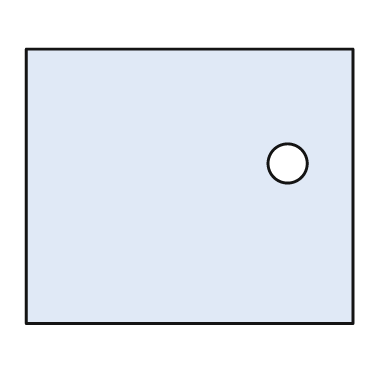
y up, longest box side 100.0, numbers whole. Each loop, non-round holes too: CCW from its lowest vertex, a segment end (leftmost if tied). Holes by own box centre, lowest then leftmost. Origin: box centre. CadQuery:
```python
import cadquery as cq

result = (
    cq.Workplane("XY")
    .moveTo(-50.0, -42.0)
    .lineTo(50.0, -42.0)
    .lineTo(50.0, 42.0)
    .lineTo(-50.0, 42.0)
    .close()
    .moveTo(30.0, 7.0)
    .circle(6.0)
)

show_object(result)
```